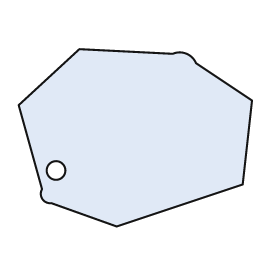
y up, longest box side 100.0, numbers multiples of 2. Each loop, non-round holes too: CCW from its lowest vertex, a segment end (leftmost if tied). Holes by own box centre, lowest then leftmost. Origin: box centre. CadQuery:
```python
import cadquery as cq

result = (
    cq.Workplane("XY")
    .moveTo(-8.0, -38.0)
    .lineTo(46.0, -20.0)
    .lineTo(50.0, 16.0)
    .lineTo(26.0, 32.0)
    .threePointArc((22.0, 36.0), (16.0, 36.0))
    .lineTo(-24.0, 38.0)
    .lineTo(-50.0, 14.0)
    .lineTo(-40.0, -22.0)
    .threePointArc((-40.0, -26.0), (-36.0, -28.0))
    .close()
    .moveTo(-34.0, -14.0)
    .circle(4.0)
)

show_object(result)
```